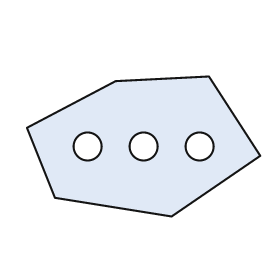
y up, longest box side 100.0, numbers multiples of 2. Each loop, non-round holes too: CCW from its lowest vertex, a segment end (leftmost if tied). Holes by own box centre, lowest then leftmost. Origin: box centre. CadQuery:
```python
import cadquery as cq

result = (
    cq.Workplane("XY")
    .moveTo(12.0, -30.0)
    .lineTo(50.0, -4.0)
    .lineTo(28.0, 30.0)
    .lineTo(-12.0, 28.0)
    .lineTo(-50.0, 8.0)
    .lineTo(-38.0, -22.0)
    .close()
    .moveTo(-24.0, 0.0)
    .circle(6.0)
    .moveTo(0.0, 0.0)
    .circle(6.0)
    .moveTo(24.0, 0.0)
    .circle(6.0)
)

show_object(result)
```